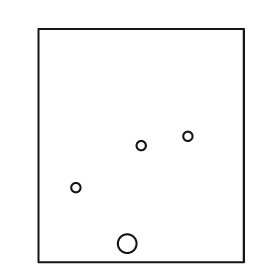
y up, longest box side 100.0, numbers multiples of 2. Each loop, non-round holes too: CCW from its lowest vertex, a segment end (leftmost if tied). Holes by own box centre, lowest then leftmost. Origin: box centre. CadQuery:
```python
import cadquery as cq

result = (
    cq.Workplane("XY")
    .moveTo(-44.0, -50.0)
    .lineTo(44.0, -50.0)
    .lineTo(44.0, 50.0)
    .lineTo(-44.0, 50.0)
    .close()
    .moveTo(-6.0, -42.0)
    .circle(4.0)
    .moveTo(-28.0, -18.0)
    .circle(2.0)
    .moveTo(0.0, 0.0)
    .circle(2.0)
    .moveTo(20.0, 4.0)
    .circle(2.0)
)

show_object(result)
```